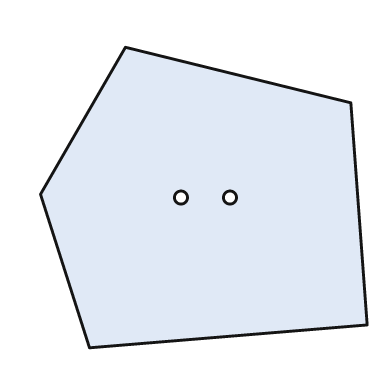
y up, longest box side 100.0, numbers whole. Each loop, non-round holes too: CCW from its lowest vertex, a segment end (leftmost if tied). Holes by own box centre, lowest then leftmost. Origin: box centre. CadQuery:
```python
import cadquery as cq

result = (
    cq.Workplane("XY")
    .moveTo(-35.0, -46.0)
    .lineTo(50.0, -39.0)
    .lineTo(45.0, 29.0)
    .lineTo(-24.0, 46.0)
    .lineTo(-50.0, 1.0)
    .close()
    .moveTo(-7.0, 0.0)
    .circle(2.0)
    .moveTo(8.0, 0.0)
    .circle(2.0)
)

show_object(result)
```